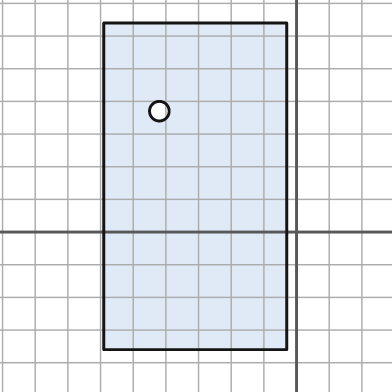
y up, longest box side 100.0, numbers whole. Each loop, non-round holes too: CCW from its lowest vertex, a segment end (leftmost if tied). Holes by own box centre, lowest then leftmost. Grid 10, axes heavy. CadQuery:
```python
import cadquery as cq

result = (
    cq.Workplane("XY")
    .moveTo(-59.0, -36.0)
    .lineTo(-3.0, -36.0)
    .lineTo(-3.0, 64.0)
    .lineTo(-59.0, 64.0)
    .close()
    .moveTo(-42.0, 37.0)
    .circle(3.0)
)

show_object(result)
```